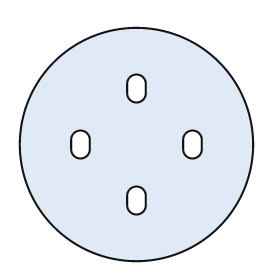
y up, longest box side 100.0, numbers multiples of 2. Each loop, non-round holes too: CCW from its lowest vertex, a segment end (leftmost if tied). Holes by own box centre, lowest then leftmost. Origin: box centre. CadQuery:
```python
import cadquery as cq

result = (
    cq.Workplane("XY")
    .moveTo(0.0, 0.0)
    .circle(50.0)
    .moveTo(-4.0, -26.0)
    .threePointArc((0.0, -30.0), (4.0, -26.0))
    .lineTo(4.0, -22.0)
    .threePointArc((0.0, -18.0), (-4.0, -22.0))
    .close()
    .moveTo(-28.0, -2.0)
    .threePointArc((-24.0, -6.0), (-20.0, -2.0))
    .lineTo(-20.0, 2.0)
    .threePointArc((-24.0, 6.0), (-28.0, 2.0))
    .close()
    .moveTo(20.0, -2.0)
    .threePointArc((24.0, -6.0), (28.0, -2.0))
    .lineTo(28.0, 2.0)
    .threePointArc((24.0, 6.0), (20.0, 2.0))
    .close()
    .moveTo(-4.0, 22.0)
    .threePointArc((0.0, 18.0), (4.0, 22.0))
    .lineTo(4.0, 26.0)
    .threePointArc((0.0, 30.0), (-4.0, 26.0))
    .close()
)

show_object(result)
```